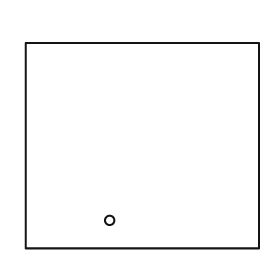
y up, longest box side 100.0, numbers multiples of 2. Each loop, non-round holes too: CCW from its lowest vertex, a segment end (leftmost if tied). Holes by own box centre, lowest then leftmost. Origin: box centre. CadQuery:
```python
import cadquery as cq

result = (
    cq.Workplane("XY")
    .moveTo(-50.0, -44.0)
    .lineTo(50.0, -44.0)
    .lineTo(50.0, 44.0)
    .lineTo(-50.0, 44.0)
    .close()
    .moveTo(-14.0, -32.0)
    .circle(2.0)
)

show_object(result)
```